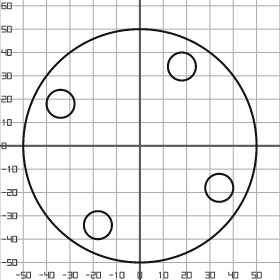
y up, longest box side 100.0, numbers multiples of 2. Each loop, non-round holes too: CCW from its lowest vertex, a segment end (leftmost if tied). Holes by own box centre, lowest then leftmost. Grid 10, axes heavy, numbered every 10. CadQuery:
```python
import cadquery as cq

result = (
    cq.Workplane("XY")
    .moveTo(0.0, 0.0)
    .circle(50.0)
    .moveTo(-18.0, -34.0)
    .circle(6.0)
    .moveTo(34.0, -18.0)
    .circle(6.0)
    .moveTo(-34.0, 18.0)
    .circle(6.0)
    .moveTo(18.0, 34.0)
    .circle(6.0)
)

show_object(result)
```